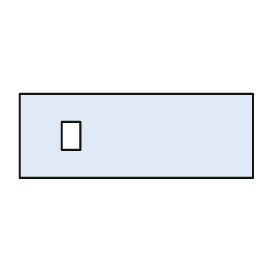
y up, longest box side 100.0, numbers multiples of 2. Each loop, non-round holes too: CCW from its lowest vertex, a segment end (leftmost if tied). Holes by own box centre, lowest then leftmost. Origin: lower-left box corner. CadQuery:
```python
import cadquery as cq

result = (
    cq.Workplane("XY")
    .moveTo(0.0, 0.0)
    .lineTo(100.0, 0.0)
    .lineTo(100.0, 36.0)
    .lineTo(0.0, 36.0)
    .close()
    .moveTo(18.0, 12.0)
    .lineTo(26.0, 12.0)
    .lineTo(26.0, 24.0)
    .lineTo(18.0, 24.0)
    .close()
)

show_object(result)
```